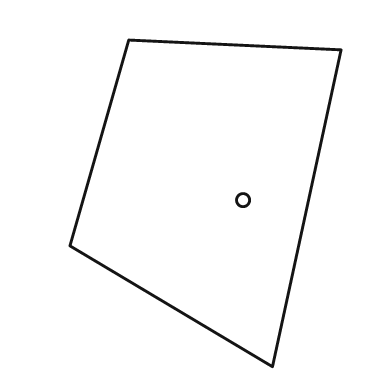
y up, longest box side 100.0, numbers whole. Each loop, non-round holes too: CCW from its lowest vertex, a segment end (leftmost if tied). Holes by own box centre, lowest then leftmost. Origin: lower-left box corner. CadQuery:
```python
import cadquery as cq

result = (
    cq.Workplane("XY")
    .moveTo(62.0, 0.0)
    .lineTo(83.0, 97.0)
    .lineTo(18.0, 100.0)
    .lineTo(0.0, 37.0)
    .close()
    .moveTo(53.0, 51.0)
    .circle(2.0)
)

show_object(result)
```